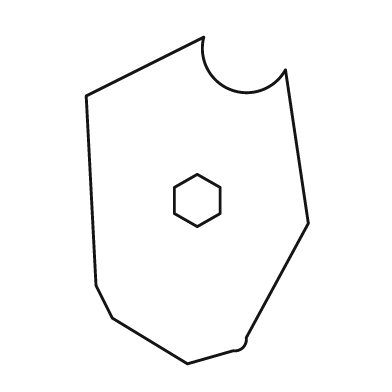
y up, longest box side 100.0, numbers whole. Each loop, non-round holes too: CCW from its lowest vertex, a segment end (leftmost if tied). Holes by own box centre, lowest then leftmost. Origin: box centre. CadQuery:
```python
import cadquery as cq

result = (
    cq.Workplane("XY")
    .moveTo(-3.0, -50.0)
    .lineTo(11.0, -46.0)
    .threePointArc((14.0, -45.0), (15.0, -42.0))
    .lineTo(34.0, -7.0)
    .lineTo(27.0, 40.0)
    .threePointArc((10.0, 34.0), (2.0, 50.0))
    .lineTo(-34.0, 32.0)
    .lineTo(-31.0, -26.0)
    .lineTo(-26.0, -36.0)
    .close()
    .moveTo(0.0, -8.0)
    .lineTo(7.0, -4.0)
    .lineTo(7.0, 4.0)
    .lineTo(0.0, 8.0)
    .lineTo(-7.0, 4.0)
    .lineTo(-7.0, -4.0)
    .close()
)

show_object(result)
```